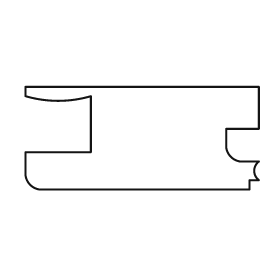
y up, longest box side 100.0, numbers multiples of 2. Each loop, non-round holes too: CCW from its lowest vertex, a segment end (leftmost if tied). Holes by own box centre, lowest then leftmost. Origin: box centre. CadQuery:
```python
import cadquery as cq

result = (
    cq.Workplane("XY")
    .moveTo(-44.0, -22.0)
    .lineTo(46.0, -22.0)
    .lineTo(46.0, -18.0)
    .lineTo(50.0, -18.0)
    .threePointArc((48.0, -14.0), (50.0, -10.0))
    .lineTo(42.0, -10.0)
    .threePointArc((38.0, -8.0), (36.0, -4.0))
    .lineTo(36.0, 4.0)
    .lineTo(50.0, 4.0)
    .lineTo(50.0, 22.0)
    .lineTo(-50.0, 22.0)
    .lineTo(-50.0, 18.0)
    .threePointArc((-36.0, 16.0), (-22.0, 18.0))
    .lineTo(-22.0, -6.0)
    .lineTo(-50.0, -6.0)
    .lineTo(-50.0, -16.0)
    .threePointArc((-48.0, -20.0), (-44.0, -22.0))
    .close()
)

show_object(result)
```